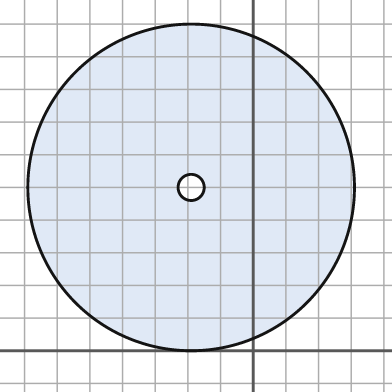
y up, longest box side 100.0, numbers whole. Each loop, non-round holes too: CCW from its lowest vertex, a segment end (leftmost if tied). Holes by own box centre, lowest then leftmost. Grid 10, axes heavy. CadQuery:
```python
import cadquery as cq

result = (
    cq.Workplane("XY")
    .moveTo(-19.0, 50.0)
    .circle(50.0)
    .moveTo(-19.0, 50.0)
    .circle(4.0)
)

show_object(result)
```